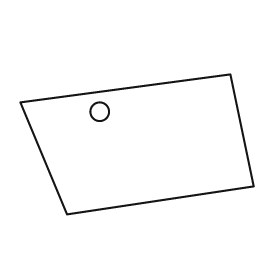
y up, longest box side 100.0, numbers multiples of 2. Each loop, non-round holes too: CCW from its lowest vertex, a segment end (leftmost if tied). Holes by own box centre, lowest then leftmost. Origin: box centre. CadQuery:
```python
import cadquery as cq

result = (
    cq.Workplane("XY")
    .moveTo(-30.0, -30.0)
    .lineTo(50.0, -18.0)
    .lineTo(40.0, 30.0)
    .lineTo(-50.0, 18.0)
    .close()
    .moveTo(-16.0, 14.0)
    .circle(4.0)
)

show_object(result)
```